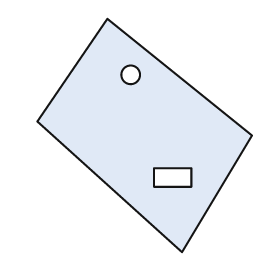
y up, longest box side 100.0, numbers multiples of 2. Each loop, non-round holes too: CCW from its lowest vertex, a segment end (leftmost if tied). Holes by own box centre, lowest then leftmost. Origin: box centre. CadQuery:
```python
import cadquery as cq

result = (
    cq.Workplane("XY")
    .moveTo(16.0, -50.0)
    .lineTo(46.0, 0.0)
    .lineTo(-16.0, 50.0)
    .lineTo(-46.0, 6.0)
    .close()
    .moveTo(4.0, -22.0)
    .lineTo(20.0, -22.0)
    .lineTo(20.0, -14.0)
    .lineTo(4.0, -14.0)
    .close()
    .moveTo(-6.0, 26.0)
    .circle(4.0)
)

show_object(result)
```